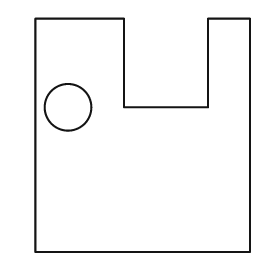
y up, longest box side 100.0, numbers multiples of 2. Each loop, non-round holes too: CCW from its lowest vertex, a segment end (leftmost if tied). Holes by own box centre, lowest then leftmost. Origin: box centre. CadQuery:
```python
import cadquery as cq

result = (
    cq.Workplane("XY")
    .moveTo(-46.0, -50.0)
    .lineTo(46.0, -50.0)
    .lineTo(46.0, 50.0)
    .lineTo(28.0, 50.0)
    .lineTo(28.0, 12.0)
    .lineTo(-8.0, 12.0)
    .lineTo(-8.0, 50.0)
    .lineTo(-46.0, 50.0)
    .close()
    .moveTo(-32.0, 12.0)
    .circle(10.0)
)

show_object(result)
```